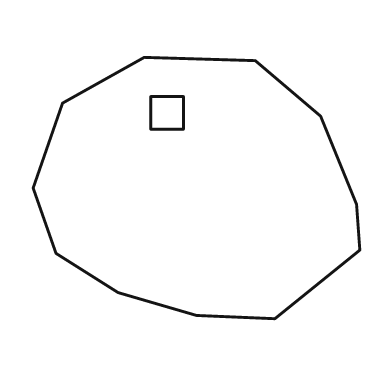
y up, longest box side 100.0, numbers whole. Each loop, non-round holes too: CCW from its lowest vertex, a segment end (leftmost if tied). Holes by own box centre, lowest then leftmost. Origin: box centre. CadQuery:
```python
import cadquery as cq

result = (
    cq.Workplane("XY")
    .moveTo(24.0, -40.0)
    .lineTo(50.0, -19.0)
    .lineTo(49.0, -5.0)
    .lineTo(38.0, 22.0)
    .lineTo(18.0, 39.0)
    .lineTo(-16.0, 40.0)
    .lineTo(-41.0, 26.0)
    .lineTo(-50.0, 0.0)
    .lineTo(-43.0, -20.0)
    .lineTo(-24.0, -32.0)
    .lineTo(0.0, -39.0)
    .close()
    .moveTo(-14.0, 18.0)
    .lineTo(-4.0, 18.0)
    .lineTo(-4.0, 28.0)
    .lineTo(-14.0, 28.0)
    .close()
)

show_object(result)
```